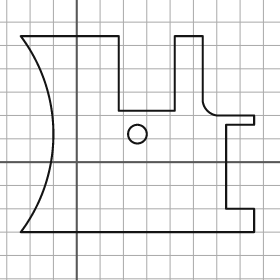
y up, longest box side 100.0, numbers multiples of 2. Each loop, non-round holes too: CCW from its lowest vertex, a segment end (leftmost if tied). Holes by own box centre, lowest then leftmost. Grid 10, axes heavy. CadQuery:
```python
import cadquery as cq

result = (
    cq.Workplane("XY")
    .moveTo(-24.0, -30.0)
    .lineTo(76.0, -30.0)
    .lineTo(76.0, -20.0)
    .lineTo(64.0, -20.0)
    .lineTo(64.0, 16.0)
    .lineTo(76.0, 16.0)
    .lineTo(76.0, 20.0)
    .lineTo(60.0, 20.0)
    .threePointArc((56.0, 22.0), (54.0, 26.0))
    .lineTo(54.0, 54.0)
    .lineTo(42.0, 54.0)
    .lineTo(42.0, 22.0)
    .lineTo(18.0, 22.0)
    .lineTo(18.0, 54.0)
    .lineTo(-24.0, 54.0)
    .threePointArc((-10.0, 12.0), (-24.0, -30.0))
    .close()
    .moveTo(26.0, 12.0)
    .circle(4.0)
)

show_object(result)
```